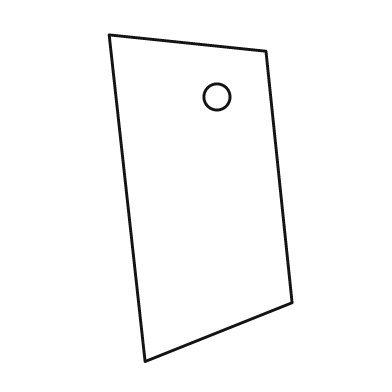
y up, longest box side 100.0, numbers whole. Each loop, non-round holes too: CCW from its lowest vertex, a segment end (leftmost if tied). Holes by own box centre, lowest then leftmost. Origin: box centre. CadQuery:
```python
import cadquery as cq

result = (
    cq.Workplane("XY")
    .moveTo(-17.0, -50.0)
    .lineTo(28.0, -32.0)
    .lineTo(20.0, 45.0)
    .lineTo(-28.0, 50.0)
    .close()
    .moveTo(5.0, 31.0)
    .circle(4.0)
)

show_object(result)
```